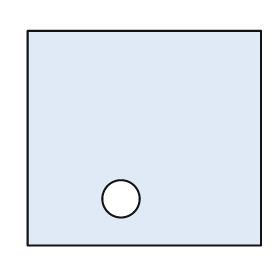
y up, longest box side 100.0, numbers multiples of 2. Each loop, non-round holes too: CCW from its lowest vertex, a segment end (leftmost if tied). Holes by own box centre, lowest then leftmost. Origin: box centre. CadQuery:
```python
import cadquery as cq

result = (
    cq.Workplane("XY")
    .moveTo(-50.0, -46.0)
    .lineTo(50.0, -46.0)
    .lineTo(50.0, 46.0)
    .lineTo(-50.0, 46.0)
    .close()
    .moveTo(-10.0, -26.0)
    .circle(8.0)
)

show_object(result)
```